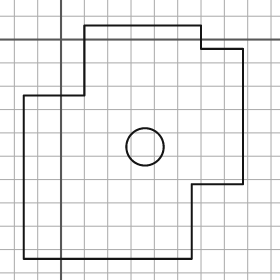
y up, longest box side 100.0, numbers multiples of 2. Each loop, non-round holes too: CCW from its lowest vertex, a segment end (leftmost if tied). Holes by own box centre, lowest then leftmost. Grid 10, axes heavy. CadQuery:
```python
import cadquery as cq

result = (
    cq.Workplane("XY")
    .moveTo(-16.0, -94.0)
    .lineTo(56.0, -94.0)
    .lineTo(56.0, -62.0)
    .lineTo(78.0, -62.0)
    .lineTo(78.0, -4.0)
    .lineTo(60.0, -4.0)
    .lineTo(60.0, 6.0)
    .lineTo(10.0, 6.0)
    .lineTo(10.0, -24.0)
    .lineTo(-16.0, -24.0)
    .close()
    .moveTo(36.0, -46.0)
    .circle(8.0)
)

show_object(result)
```